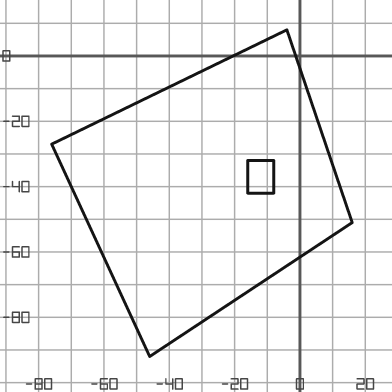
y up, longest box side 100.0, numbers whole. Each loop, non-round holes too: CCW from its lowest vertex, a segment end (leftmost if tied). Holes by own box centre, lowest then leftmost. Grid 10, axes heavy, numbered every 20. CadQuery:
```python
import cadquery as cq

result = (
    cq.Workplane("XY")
    .moveTo(-46.0, -92.0)
    .lineTo(16.0, -51.0)
    .lineTo(-4.0, 8.0)
    .lineTo(-76.0, -27.0)
    .close()
    .moveTo(-16.0, -42.0)
    .lineTo(-8.0, -42.0)
    .lineTo(-8.0, -32.0)
    .lineTo(-16.0, -32.0)
    .close()
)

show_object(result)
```